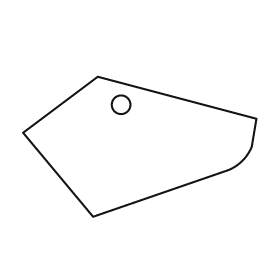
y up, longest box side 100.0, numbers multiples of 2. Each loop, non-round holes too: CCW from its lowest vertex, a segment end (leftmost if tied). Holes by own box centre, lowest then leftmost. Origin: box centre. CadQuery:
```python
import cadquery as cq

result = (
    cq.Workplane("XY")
    .moveTo(-20.0, -30.0)
    .lineTo(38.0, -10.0)
    .threePointArc((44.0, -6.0), (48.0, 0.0))
    .lineTo(50.0, 12.0)
    .lineTo(-18.0, 30.0)
    .lineTo(-50.0, 6.0)
    .close()
    .moveTo(-8.0, 18.0)
    .circle(4.0)
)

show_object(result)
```